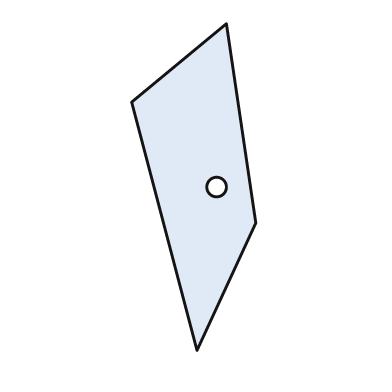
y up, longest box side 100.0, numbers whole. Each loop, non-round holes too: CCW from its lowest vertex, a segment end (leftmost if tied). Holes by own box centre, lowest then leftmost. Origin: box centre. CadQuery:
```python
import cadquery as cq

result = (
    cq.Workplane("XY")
    .moveTo(1.0, -50.0)
    .lineTo(19.0, -11.0)
    .lineTo(10.0, 50.0)
    .lineTo(-19.0, 26.0)
    .close()
    .moveTo(7.0, 0.0)
    .circle(3.0)
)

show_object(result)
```